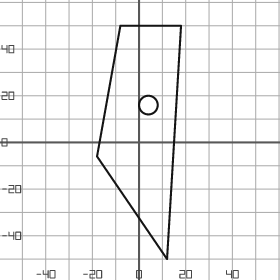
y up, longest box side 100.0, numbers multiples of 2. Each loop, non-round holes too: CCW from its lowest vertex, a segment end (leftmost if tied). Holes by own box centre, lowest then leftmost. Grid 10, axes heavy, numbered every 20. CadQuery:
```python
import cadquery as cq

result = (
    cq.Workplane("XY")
    .moveTo(12.0, -50.0)
    .lineTo(18.0, 50.0)
    .lineTo(-8.0, 50.0)
    .lineTo(-18.0, -6.0)
    .close()
    .moveTo(4.0, 16.0)
    .circle(4.0)
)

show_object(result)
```